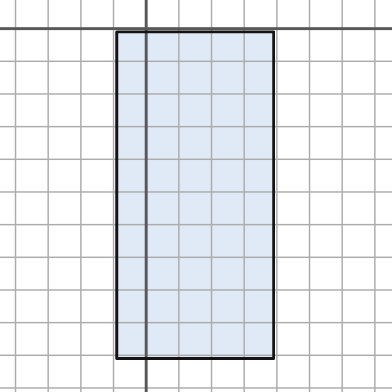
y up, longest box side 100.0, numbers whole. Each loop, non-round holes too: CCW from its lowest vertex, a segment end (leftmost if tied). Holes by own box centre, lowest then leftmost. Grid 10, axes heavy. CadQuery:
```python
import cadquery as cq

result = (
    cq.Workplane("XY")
    .moveTo(-9.0, -101.0)
    .lineTo(39.0, -101.0)
    .lineTo(39.0, -1.0)
    .lineTo(-9.0, -1.0)
    .close()
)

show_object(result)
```